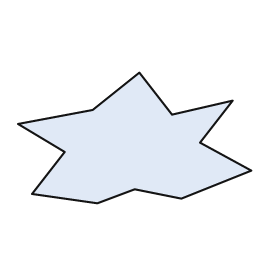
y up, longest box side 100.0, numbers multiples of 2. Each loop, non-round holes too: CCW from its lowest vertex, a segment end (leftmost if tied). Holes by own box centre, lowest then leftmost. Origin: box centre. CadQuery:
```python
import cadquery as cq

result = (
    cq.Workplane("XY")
    .moveTo(-16.0, -28.0)
    .lineTo(0.0, -22.0)
    .lineTo(20.0, -26.0)
    .lineTo(50.0, -14.0)
    .lineTo(28.0, -2.0)
    .lineTo(42.0, 16.0)
    .lineTo(16.0, 10.0)
    .lineTo(2.0, 28.0)
    .lineTo(-18.0, 12.0)
    .lineTo(-50.0, 6.0)
    .lineTo(-30.0, -6.0)
    .lineTo(-44.0, -24.0)
    .close()
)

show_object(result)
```